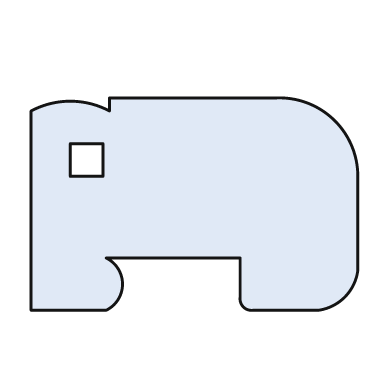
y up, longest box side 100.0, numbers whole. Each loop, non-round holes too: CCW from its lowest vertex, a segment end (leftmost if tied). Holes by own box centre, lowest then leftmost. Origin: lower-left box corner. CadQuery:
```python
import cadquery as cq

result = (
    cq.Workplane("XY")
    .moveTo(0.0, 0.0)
    .lineTo(23.0, 0.0)
    .threePointArc((28.0, 8.0), (23.0, 16.0))
    .lineTo(64.0, 16.0)
    .lineTo(64.0, 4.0)
    .threePointArc((65.0, 1.0), (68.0, 0.0))
    .lineTo(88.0, 0.0)
    .threePointArc((96.0, 4.0), (100.0, 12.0))
    .lineTo(100.0, 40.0)
    .threePointArc((93.0, 58.0), (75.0, 65.0))
    .lineTo(24.0, 65.0)
    .lineTo(24.0, 61.0)
    .threePointArc((12.0, 64.0), (0.0, 61.0))
    .close()
    .moveTo(12.0, 41.0)
    .lineTo(22.0, 41.0)
    .lineTo(22.0, 51.0)
    .lineTo(12.0, 51.0)
    .close()
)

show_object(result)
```